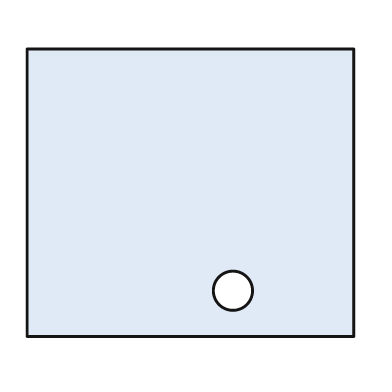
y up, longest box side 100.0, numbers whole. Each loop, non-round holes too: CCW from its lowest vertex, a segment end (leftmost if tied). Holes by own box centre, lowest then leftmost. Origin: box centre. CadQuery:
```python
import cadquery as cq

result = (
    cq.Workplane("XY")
    .moveTo(-50.0, -44.0)
    .lineTo(50.0, -44.0)
    .lineTo(50.0, 44.0)
    .lineTo(-50.0, 44.0)
    .close()
    .moveTo(13.0, -30.0)
    .circle(6.0)
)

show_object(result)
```